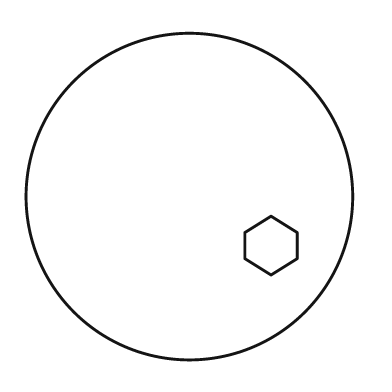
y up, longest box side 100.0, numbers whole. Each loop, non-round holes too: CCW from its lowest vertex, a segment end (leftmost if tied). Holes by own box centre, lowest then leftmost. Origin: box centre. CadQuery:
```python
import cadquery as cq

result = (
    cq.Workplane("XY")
    .moveTo(0.0, 0.0)
    .circle(50.0)
    .moveTo(25.0, -24.0)
    .lineTo(33.0, -19.0)
    .lineTo(33.0, -11.0)
    .lineTo(25.0, -6.0)
    .lineTo(17.0, -11.0)
    .lineTo(17.0, -19.0)
    .close()
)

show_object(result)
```